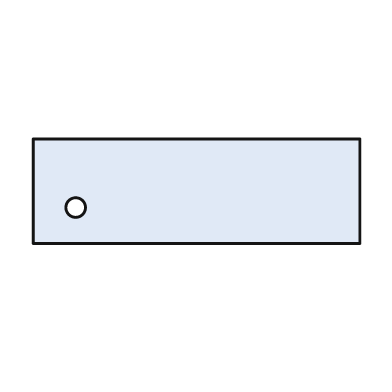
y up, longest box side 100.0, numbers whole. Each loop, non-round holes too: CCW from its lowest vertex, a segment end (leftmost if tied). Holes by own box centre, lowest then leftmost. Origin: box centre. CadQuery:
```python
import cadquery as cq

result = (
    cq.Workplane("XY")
    .moveTo(-50.0, -16.0)
    .lineTo(50.0, -16.0)
    .lineTo(50.0, 16.0)
    .lineTo(-50.0, 16.0)
    .close()
    .moveTo(-37.0, -5.0)
    .circle(3.0)
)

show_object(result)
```